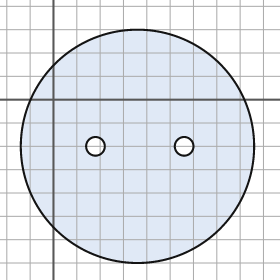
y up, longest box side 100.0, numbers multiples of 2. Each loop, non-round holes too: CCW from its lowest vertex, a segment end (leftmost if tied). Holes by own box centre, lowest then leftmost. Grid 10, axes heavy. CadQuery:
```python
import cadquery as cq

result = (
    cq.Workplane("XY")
    .moveTo(36.0, -20.0)
    .circle(50.0)
    .moveTo(18.0, -20.0)
    .circle(4.0)
    .moveTo(56.0, -20.0)
    .circle(4.0)
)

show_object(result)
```